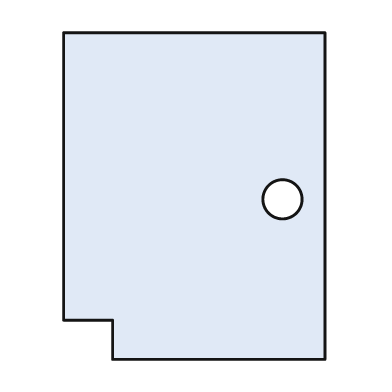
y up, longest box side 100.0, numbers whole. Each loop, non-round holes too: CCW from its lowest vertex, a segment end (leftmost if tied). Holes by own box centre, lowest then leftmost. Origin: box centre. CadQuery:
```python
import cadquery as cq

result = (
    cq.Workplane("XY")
    .moveTo(-25.0, -50.0)
    .lineTo(40.0, -50.0)
    .lineTo(40.0, 50.0)
    .lineTo(-40.0, 50.0)
    .lineTo(-40.0, -38.0)
    .lineTo(-25.0, -38.0)
    .close()
    .moveTo(27.0, -1.0)
    .circle(6.0)
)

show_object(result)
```